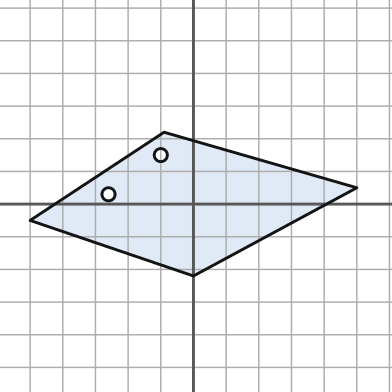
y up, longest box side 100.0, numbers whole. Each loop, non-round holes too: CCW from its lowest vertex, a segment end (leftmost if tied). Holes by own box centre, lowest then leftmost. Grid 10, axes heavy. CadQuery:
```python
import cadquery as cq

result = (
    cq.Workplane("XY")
    .moveTo(0.0, -22.0)
    .lineTo(50.0, 5.0)
    .lineTo(-9.0, 22.0)
    .lineTo(-50.0, -5.0)
    .close()
    .moveTo(-26.0, 3.0)
    .circle(2.0)
    .moveTo(-10.0, 15.0)
    .circle(2.0)
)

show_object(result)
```